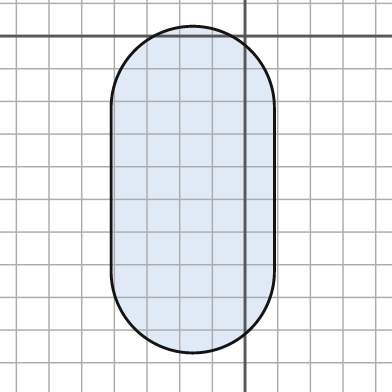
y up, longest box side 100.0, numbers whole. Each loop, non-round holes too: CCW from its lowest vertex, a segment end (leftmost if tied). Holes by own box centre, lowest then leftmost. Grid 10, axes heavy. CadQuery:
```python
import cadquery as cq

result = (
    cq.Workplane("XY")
    .moveTo(-41.0, -72.0)
    .threePointArc((-16.0, -97.0), (9.0, -72.0))
    .lineTo(9.0, -22.0)
    .threePointArc((-16.0, 3.0), (-41.0, -22.0))
    .close()
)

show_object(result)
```